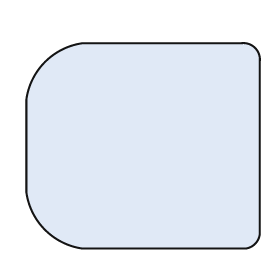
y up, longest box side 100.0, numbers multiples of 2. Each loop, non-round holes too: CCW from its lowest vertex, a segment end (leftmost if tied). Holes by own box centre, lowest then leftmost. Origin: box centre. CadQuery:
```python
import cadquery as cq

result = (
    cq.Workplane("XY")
    .moveTo(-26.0, -44.0)
    .lineTo(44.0, -44.0)
    .threePointArc((48.0, -42.0), (50.0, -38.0))
    .lineTo(50.0, 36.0)
    .threePointArc((48.0, 42.0), (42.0, 44.0))
    .lineTo(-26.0, 44.0)
    .threePointArc((-42.0, 36.0), (-50.0, 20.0))
    .lineTo(-50.0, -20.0)
    .threePointArc((-42.0, -36.0), (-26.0, -44.0))
    .close()
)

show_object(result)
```